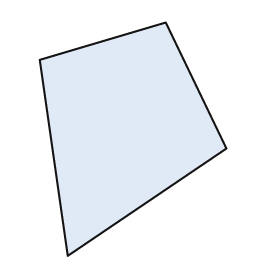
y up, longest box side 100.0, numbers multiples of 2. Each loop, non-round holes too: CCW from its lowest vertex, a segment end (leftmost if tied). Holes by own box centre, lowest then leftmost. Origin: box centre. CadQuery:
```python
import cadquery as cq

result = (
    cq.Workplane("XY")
    .moveTo(-28.0, -50.0)
    .lineTo(40.0, -4.0)
    .lineTo(14.0, 50.0)
    .lineTo(-40.0, 34.0)
    .close()
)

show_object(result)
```